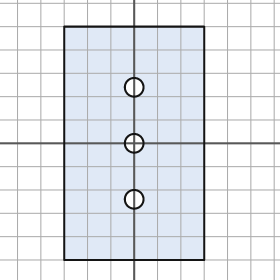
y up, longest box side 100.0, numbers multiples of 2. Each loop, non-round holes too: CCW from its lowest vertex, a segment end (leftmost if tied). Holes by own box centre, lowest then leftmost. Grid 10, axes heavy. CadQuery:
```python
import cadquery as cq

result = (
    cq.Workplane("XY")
    .moveTo(-30.0, -50.0)
    .lineTo(30.0, -50.0)
    .lineTo(30.0, 50.0)
    .lineTo(-30.0, 50.0)
    .close()
    .moveTo(0.0, -24.0)
    .circle(4.0)
    .moveTo(0.0, 0.0)
    .circle(4.0)
    .moveTo(0.0, 24.0)
    .circle(4.0)
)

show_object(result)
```